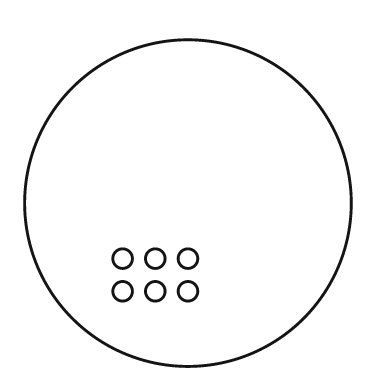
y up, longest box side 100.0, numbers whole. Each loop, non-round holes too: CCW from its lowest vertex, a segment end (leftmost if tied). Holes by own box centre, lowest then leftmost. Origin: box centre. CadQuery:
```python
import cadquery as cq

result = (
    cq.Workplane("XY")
    .moveTo(0.0, 0.0)
    .circle(50.0)
    .moveTo(-20.0, -27.0)
    .circle(3.0)
    .moveTo(-10.0, -27.0)
    .circle(3.0)
    .moveTo(0.0, -27.0)
    .circle(3.0)
    .moveTo(-20.0, -17.0)
    .circle(3.0)
    .moveTo(-10.0, -17.0)
    .circle(3.0)
    .moveTo(0.0, -17.0)
    .circle(3.0)
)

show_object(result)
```